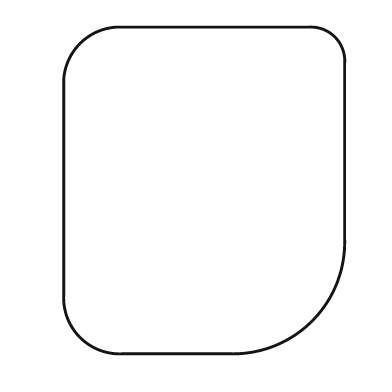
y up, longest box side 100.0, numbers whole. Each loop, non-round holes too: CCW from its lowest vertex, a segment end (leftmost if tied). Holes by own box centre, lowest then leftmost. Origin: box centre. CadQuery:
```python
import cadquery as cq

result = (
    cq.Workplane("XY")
    .moveTo(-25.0, -50.0)
    .lineTo(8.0, -50.0)
    .threePointArc((33.0, -40.0), (43.0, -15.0))
    .lineTo(43.0, 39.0)
    .threePointArc((40.0, 47.0), (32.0, 50.0))
    .lineTo(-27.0, 50.0)
    .threePointArc((-38.0, 45.0), (-43.0, 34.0))
    .lineTo(-43.0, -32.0)
    .threePointArc((-38.0, -45.0), (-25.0, -50.0))
    .close()
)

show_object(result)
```